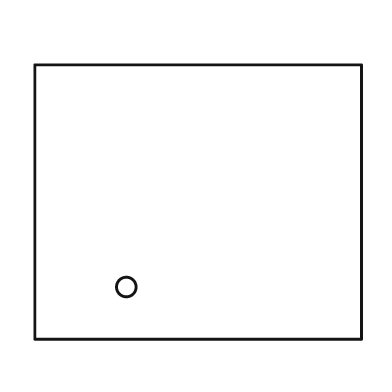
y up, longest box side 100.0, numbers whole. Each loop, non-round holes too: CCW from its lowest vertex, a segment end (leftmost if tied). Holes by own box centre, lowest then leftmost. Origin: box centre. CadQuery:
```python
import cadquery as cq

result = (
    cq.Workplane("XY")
    .moveTo(-50.0, -42.0)
    .lineTo(50.0, -42.0)
    .lineTo(50.0, 42.0)
    .lineTo(-50.0, 42.0)
    .close()
    .moveTo(-22.0, -26.0)
    .circle(3.0)
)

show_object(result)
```